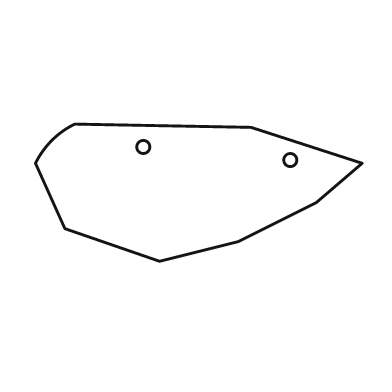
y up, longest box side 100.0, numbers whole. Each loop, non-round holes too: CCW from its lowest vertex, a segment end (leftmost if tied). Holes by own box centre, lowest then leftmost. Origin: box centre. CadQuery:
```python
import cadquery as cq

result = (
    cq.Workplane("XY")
    .moveTo(-12.0, -21.0)
    .lineTo(12.0, -15.0)
    .lineTo(36.0, -3.0)
    .lineTo(50.0, 9.0)
    .lineTo(16.0, 20.0)
    .lineTo(-38.0, 21.0)
    .threePointArc((-45.0, 16.0), (-50.0, 9.0))
    .lineTo(-41.0, -11.0)
    .close()
    .moveTo(28.0, 10.0)
    .circle(2.0)
    .moveTo(-17.0, 14.0)
    .circle(2.0)
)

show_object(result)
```